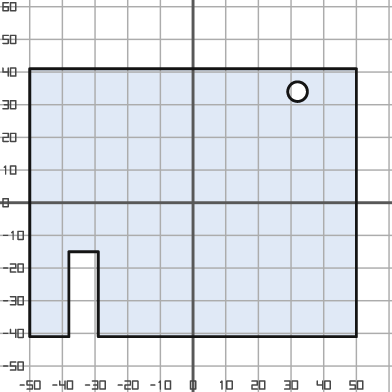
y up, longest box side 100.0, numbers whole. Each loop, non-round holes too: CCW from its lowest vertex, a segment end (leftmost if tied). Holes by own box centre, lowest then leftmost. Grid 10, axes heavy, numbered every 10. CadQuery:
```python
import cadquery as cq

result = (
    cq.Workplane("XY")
    .moveTo(-50.0, -41.0)
    .lineTo(-38.0, -41.0)
    .lineTo(-38.0, -15.0)
    .lineTo(-29.0, -15.0)
    .lineTo(-29.0, -41.0)
    .lineTo(50.0, -41.0)
    .lineTo(50.0, 41.0)
    .lineTo(-50.0, 41.0)
    .close()
    .moveTo(32.0, 34.0)
    .circle(3.0)
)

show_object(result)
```